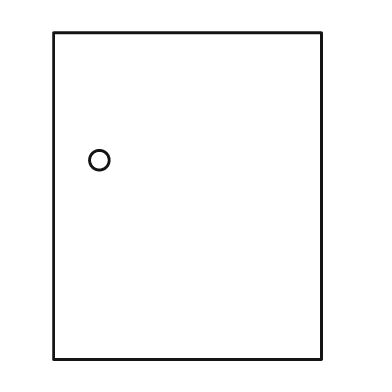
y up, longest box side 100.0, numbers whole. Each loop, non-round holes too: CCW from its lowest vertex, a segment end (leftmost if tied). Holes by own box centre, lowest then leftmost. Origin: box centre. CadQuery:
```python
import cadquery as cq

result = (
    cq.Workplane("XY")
    .moveTo(-41.0, -50.0)
    .lineTo(41.0, -50.0)
    .lineTo(41.0, 50.0)
    .lineTo(-41.0, 50.0)
    .close()
    .moveTo(-27.0, 11.0)
    .circle(3.0)
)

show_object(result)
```